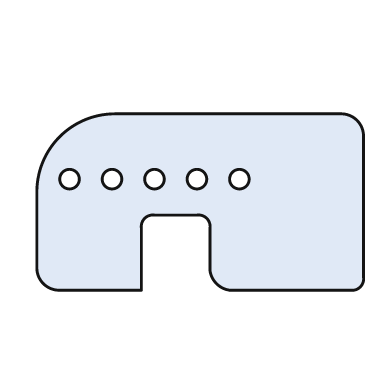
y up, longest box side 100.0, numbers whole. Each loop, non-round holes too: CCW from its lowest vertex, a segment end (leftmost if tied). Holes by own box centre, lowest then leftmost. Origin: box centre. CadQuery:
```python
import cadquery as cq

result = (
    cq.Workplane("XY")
    .moveTo(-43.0, -27.0)
    .lineTo(-18.0, -27.0)
    .lineTo(-18.0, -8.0)
    .threePointArc((-17.0, -5.0), (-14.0, -4.0))
    .lineTo(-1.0, -4.0)
    .threePointArc((2.0, -5.0), (3.0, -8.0))
    .lineTo(3.0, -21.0)
    .threePointArc((5.0, -25.0), (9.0, -27.0))
    .lineTo(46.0, -27.0)
    .threePointArc((49.0, -26.0), (50.0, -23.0))
    .lineTo(50.0, 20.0)
    .threePointArc((48.0, 25.0), (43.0, 27.0))
    .lineTo(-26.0, 27.0)
    .threePointArc((-43.0, 20.0), (-50.0, 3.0))
    .lineTo(-50.0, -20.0)
    .threePointArc((-48.0, -25.0), (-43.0, -27.0))
    .close()
    .moveTo(-40.0, 7.0)
    .circle(3.0)
    .moveTo(-27.0, 7.0)
    .circle(3.0)
    .moveTo(-14.0, 7.0)
    .circle(3.0)
    .moveTo(-1.0, 7.0)
    .circle(3.0)
    .moveTo(12.0, 7.0)
    .circle(3.0)
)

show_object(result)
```